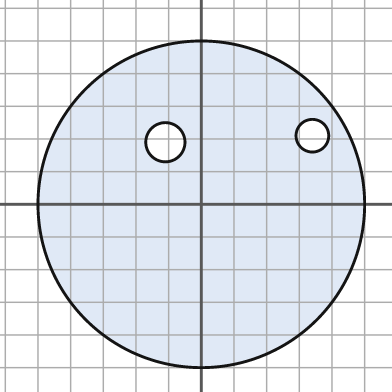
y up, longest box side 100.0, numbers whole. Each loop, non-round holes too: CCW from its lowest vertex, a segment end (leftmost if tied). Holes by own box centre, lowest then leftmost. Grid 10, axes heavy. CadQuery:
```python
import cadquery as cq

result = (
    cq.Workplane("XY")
    .moveTo(0.0, 0.0)
    .circle(50.0)
    .moveTo(-11.0, 19.0)
    .circle(6.0)
    .moveTo(34.0, 21.0)
    .circle(5.0)
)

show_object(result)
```